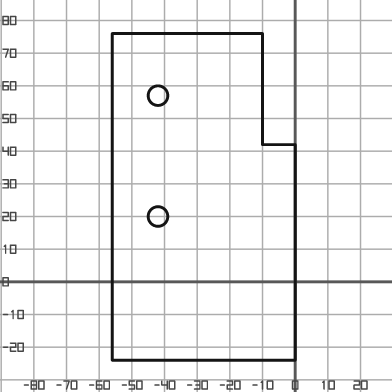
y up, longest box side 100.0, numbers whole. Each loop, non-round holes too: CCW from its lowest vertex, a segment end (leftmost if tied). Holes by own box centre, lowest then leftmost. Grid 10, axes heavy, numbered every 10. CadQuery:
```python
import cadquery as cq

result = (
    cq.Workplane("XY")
    .moveTo(-56.0, -24.0)
    .lineTo(0.0, -24.0)
    .lineTo(0.0, 42.0)
    .lineTo(-10.0, 42.0)
    .lineTo(-10.0, 76.0)
    .lineTo(-56.0, 76.0)
    .close()
    .moveTo(-42.0, 20.0)
    .circle(3.0)
    .moveTo(-42.0, 57.0)
    .circle(3.0)
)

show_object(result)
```